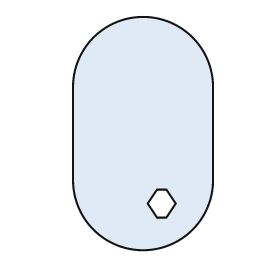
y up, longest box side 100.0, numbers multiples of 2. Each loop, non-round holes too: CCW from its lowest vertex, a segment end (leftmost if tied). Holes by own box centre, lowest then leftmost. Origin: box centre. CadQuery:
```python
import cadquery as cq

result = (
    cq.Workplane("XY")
    .moveTo(-30.0, -20.0)
    .threePointArc((0.0, -50.0), (30.0, -20.0))
    .lineTo(30.0, 20.0)
    .threePointArc((0.0, 50.0), (-30.0, 20.0))
    .close()
    .moveTo(6.0, -36.0)
    .lineTo(10.0, -36.0)
    .lineTo(14.0, -30.0)
    .lineTo(10.0, -24.0)
    .lineTo(6.0, -24.0)
    .lineTo(2.0, -30.0)
    .close()
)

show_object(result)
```